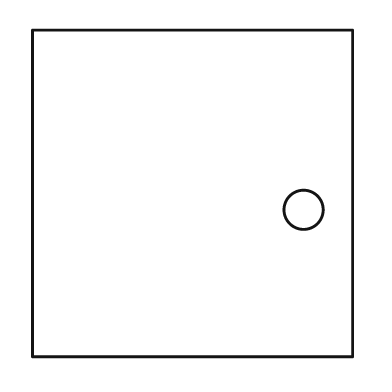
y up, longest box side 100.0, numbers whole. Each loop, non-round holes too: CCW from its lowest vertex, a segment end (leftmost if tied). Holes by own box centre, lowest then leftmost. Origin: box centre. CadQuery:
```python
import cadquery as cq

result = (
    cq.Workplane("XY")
    .moveTo(-49.0, -50.0)
    .lineTo(49.0, -50.0)
    .lineTo(49.0, 50.0)
    .lineTo(-49.0, 50.0)
    .close()
    .moveTo(34.0, -5.0)
    .circle(6.0)
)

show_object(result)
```